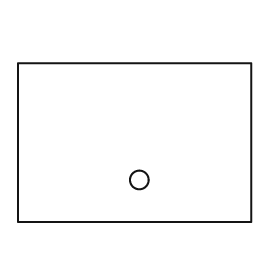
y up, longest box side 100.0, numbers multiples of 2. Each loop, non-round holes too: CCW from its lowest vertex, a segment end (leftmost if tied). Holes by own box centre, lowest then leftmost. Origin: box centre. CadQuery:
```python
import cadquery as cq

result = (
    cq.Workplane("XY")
    .moveTo(-50.0, -34.0)
    .lineTo(50.0, -34.0)
    .lineTo(50.0, 34.0)
    .lineTo(-50.0, 34.0)
    .close()
    .moveTo(2.0, -16.0)
    .circle(4.0)
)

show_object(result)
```